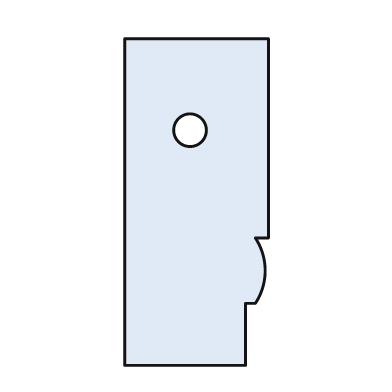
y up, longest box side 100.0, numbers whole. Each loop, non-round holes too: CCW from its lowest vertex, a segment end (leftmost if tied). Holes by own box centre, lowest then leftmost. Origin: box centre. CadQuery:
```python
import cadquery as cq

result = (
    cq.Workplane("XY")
    .moveTo(-22.0, -50.0)
    .lineTo(15.0, -50.0)
    .lineTo(15.0, -31.0)
    .lineTo(18.0, -31.0)
    .threePointArc((21.0, -21.0), (18.0, -11.0))
    .lineTo(22.0, -11.0)
    .lineTo(22.0, 50.0)
    .lineTo(-22.0, 50.0)
    .close()
    .moveTo(-2.0, 22.0)
    .circle(5.0)
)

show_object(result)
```